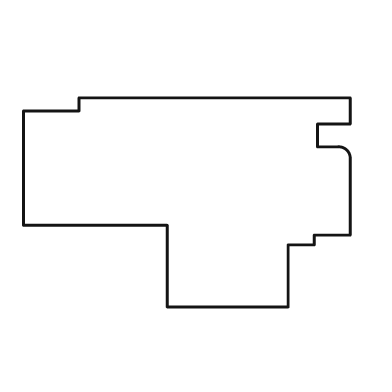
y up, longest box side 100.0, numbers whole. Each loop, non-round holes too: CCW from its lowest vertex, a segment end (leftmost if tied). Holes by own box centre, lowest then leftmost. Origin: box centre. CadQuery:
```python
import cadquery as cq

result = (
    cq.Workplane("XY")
    .moveTo(-6.0, -32.0)
    .lineTo(31.0, -32.0)
    .lineTo(31.0, -13.0)
    .lineTo(39.0, -13.0)
    .lineTo(39.0, -10.0)
    .lineTo(50.0, -10.0)
    .lineTo(50.0, 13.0)
    .threePointArc((49.0, 16.0), (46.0, 17.0))
    .lineTo(40.0, 17.0)
    .lineTo(40.0, 24.0)
    .lineTo(50.0, 24.0)
    .lineTo(50.0, 32.0)
    .lineTo(-33.0, 32.0)
    .lineTo(-33.0, 28.0)
    .lineTo(-50.0, 28.0)
    .lineTo(-50.0, -7.0)
    .lineTo(-6.0, -7.0)
    .close()
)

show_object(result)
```